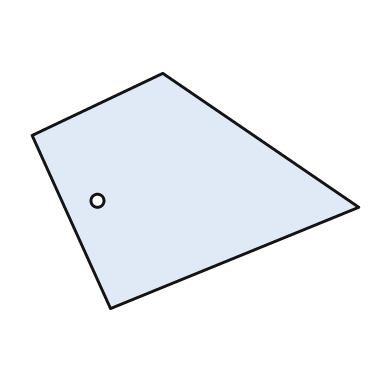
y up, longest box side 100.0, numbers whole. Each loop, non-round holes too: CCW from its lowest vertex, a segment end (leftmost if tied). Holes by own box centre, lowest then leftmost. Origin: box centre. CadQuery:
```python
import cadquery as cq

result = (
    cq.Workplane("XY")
    .moveTo(-26.0, -36.0)
    .lineTo(50.0, -5.0)
    .lineTo(-10.0, 36.0)
    .lineTo(-50.0, 17.0)
    .close()
    .moveTo(-30.0, -3.0)
    .circle(2.0)
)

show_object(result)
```